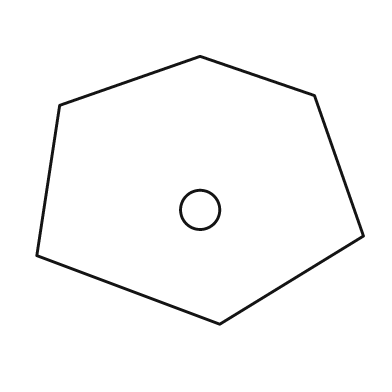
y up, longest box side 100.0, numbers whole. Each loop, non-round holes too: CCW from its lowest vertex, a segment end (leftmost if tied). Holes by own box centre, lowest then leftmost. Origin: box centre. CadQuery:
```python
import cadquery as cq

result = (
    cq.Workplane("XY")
    .moveTo(6.0, -41.0)
    .lineTo(50.0, -14.0)
    .lineTo(35.0, 29.0)
    .lineTo(0.0, 41.0)
    .lineTo(-43.0, 26.0)
    .lineTo(-50.0, -20.0)
    .close()
    .moveTo(0.0, -6.0)
    .circle(6.0)
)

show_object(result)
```